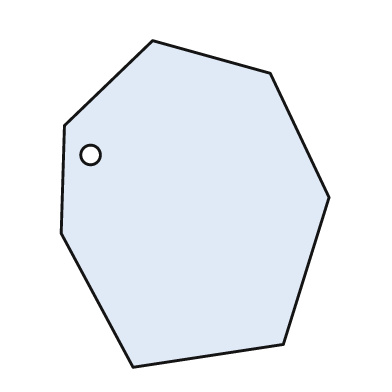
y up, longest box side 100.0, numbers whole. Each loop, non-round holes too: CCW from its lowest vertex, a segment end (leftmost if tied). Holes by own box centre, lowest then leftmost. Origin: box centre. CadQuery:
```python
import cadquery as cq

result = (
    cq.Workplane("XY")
    .moveTo(-19.0, -50.0)
    .lineTo(27.0, -43.0)
    .lineTo(41.0, 2.0)
    .lineTo(23.0, 40.0)
    .lineTo(-13.0, 50.0)
    .lineTo(-40.0, 24.0)
    .lineTo(-41.0, -9.0)
    .close()
    .moveTo(-32.0, 15.0)
    .circle(3.0)
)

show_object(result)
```